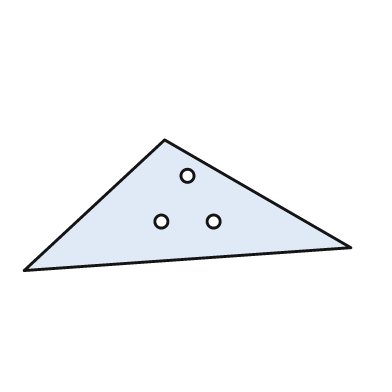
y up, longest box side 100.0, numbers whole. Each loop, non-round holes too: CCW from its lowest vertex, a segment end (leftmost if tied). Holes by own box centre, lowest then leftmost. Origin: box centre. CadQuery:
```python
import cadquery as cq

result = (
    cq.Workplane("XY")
    .moveTo(-50.0, -20.0)
    .lineTo(50.0, -13.0)
    .lineTo(-7.0, 20.0)
    .close()
    .moveTo(-8.0, -5.0)
    .circle(2.0)
    .moveTo(8.0, -5.0)
    .circle(2.0)
    .moveTo(0.0, 9.0)
    .circle(2.0)
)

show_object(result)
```